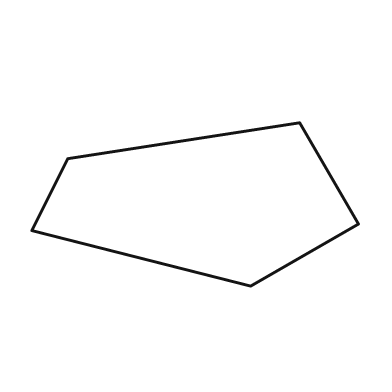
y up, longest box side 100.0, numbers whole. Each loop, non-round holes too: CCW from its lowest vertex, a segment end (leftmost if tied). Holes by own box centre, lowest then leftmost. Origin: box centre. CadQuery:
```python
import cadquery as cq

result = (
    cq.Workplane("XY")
    .moveTo(17.0, -25.0)
    .lineTo(50.0, -6.0)
    .lineTo(32.0, 25.0)
    .lineTo(-39.0, 14.0)
    .lineTo(-50.0, -8.0)
    .close()
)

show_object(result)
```